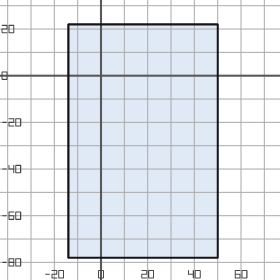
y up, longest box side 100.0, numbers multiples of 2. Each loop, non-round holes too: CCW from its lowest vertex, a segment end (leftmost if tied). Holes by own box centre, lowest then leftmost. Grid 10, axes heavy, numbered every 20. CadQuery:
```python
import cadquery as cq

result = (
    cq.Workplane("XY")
    .moveTo(-14.0, -78.0)
    .lineTo(50.0, -78.0)
    .lineTo(50.0, 22.0)
    .lineTo(-14.0, 22.0)
    .close()
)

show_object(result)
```